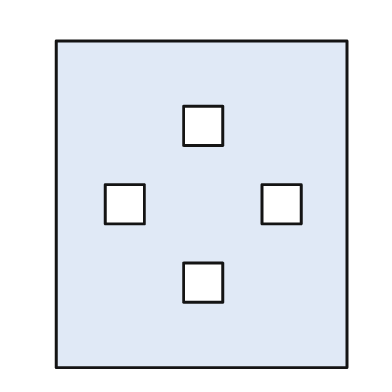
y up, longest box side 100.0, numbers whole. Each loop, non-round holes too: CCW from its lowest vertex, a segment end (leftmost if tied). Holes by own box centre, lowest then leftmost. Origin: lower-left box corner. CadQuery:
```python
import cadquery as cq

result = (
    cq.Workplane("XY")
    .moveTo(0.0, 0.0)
    .lineTo(89.0, 0.0)
    .lineTo(89.0, 100.0)
    .lineTo(0.0, 100.0)
    .close()
    .moveTo(39.0, 20.0)
    .lineTo(51.0, 20.0)
    .lineTo(51.0, 32.0)
    .lineTo(39.0, 32.0)
    .close()
    .moveTo(15.0, 44.0)
    .lineTo(27.0, 44.0)
    .lineTo(27.0, 56.0)
    .lineTo(15.0, 56.0)
    .close()
    .moveTo(63.0, 44.0)
    .lineTo(75.0, 44.0)
    .lineTo(75.0, 56.0)
    .lineTo(63.0, 56.0)
    .close()
    .moveTo(39.0, 68.0)
    .lineTo(51.0, 68.0)
    .lineTo(51.0, 80.0)
    .lineTo(39.0, 80.0)
    .close()
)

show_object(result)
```